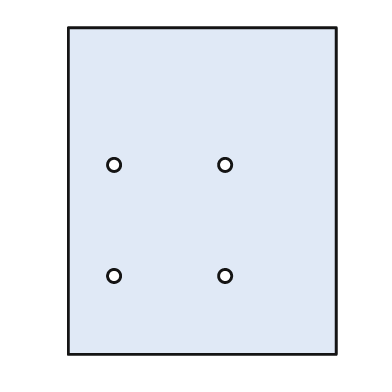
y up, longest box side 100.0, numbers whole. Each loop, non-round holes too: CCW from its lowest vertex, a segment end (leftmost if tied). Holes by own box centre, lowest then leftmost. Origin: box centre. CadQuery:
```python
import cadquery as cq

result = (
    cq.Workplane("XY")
    .moveTo(-41.0, -50.0)
    .lineTo(41.0, -50.0)
    .lineTo(41.0, 50.0)
    .lineTo(-41.0, 50.0)
    .close()
    .moveTo(-27.0, -26.0)
    .circle(2.0)
    .moveTo(7.0, -26.0)
    .circle(2.0)
    .moveTo(-27.0, 8.0)
    .circle(2.0)
    .moveTo(7.0, 8.0)
    .circle(2.0)
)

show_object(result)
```